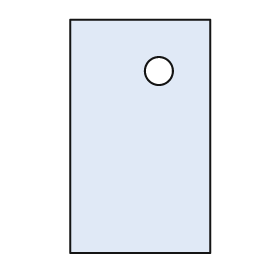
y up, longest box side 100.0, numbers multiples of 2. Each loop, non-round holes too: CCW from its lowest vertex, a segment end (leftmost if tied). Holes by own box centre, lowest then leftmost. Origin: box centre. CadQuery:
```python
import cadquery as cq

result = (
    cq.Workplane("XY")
    .moveTo(-30.0, -50.0)
    .lineTo(30.0, -50.0)
    .lineTo(30.0, 50.0)
    .lineTo(-30.0, 50.0)
    .close()
    .moveTo(8.0, 28.0)
    .circle(6.0)
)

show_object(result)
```